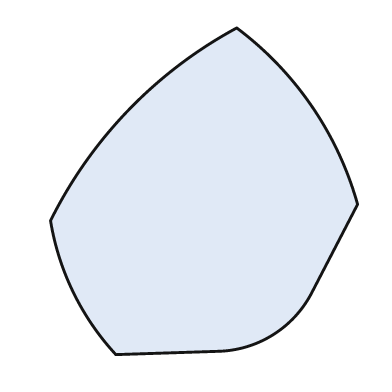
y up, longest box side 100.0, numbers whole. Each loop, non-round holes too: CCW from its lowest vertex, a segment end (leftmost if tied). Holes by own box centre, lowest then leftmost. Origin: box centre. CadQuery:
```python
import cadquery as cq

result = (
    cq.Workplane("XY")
    .moveTo(-27.0, -50.0)
    .lineTo(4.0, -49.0)
    .threePointArc((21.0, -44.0), (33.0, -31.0))
    .lineTo(47.0, -4.0)
    .threePointArc((33.0, 26.0), (10.0, 50.0))
    .threePointArc((-23.0, 25.0), (-47.0, -9.0))
    .threePointArc((-40.0, -31.0), (-27.0, -50.0))
    .close()
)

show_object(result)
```